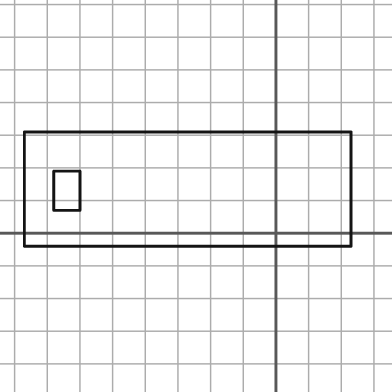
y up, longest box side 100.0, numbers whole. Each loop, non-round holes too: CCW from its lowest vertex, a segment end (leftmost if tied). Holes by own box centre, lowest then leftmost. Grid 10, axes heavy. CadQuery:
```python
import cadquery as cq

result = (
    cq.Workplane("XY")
    .moveTo(-77.0, -4.0)
    .lineTo(23.0, -4.0)
    .lineTo(23.0, 31.0)
    .lineTo(-77.0, 31.0)
    .close()
    .moveTo(-68.0, 7.0)
    .lineTo(-60.0, 7.0)
    .lineTo(-60.0, 19.0)
    .lineTo(-68.0, 19.0)
    .close()
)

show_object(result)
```